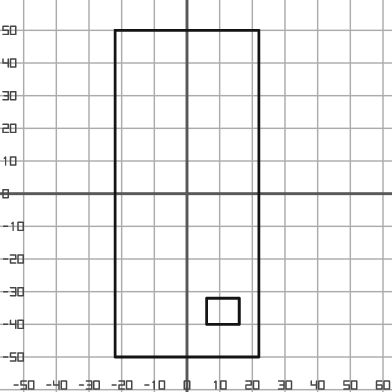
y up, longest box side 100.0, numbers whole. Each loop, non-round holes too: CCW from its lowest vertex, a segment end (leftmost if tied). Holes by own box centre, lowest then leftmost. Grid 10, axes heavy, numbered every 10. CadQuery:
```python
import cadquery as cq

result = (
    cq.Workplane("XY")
    .moveTo(-22.0, -50.0)
    .lineTo(22.0, -50.0)
    .lineTo(22.0, 50.0)
    .lineTo(-22.0, 50.0)
    .close()
    .moveTo(6.0, -40.0)
    .lineTo(16.0, -40.0)
    .lineTo(16.0, -32.0)
    .lineTo(6.0, -32.0)
    .close()
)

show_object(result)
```